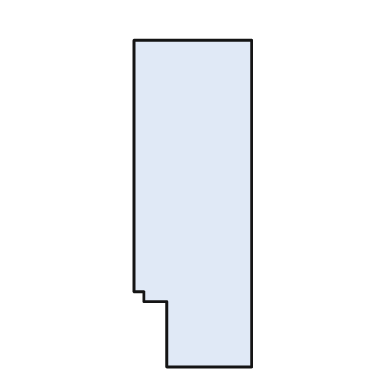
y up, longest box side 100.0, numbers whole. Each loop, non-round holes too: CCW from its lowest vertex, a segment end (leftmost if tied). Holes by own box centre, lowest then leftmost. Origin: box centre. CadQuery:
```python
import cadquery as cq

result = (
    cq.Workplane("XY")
    .moveTo(-8.0, -50.0)
    .lineTo(18.0, -50.0)
    .lineTo(18.0, 50.0)
    .lineTo(-18.0, 50.0)
    .lineTo(-18.0, -27.0)
    .lineTo(-15.0, -27.0)
    .lineTo(-15.0, -30.0)
    .lineTo(-8.0, -30.0)
    .close()
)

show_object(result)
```